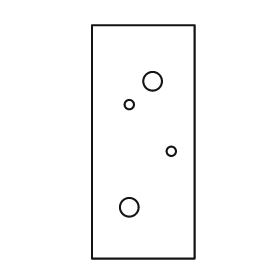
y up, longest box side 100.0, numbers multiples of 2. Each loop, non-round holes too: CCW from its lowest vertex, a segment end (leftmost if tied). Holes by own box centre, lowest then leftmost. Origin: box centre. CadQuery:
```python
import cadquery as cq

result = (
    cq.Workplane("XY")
    .moveTo(-22.0, -50.0)
    .lineTo(22.0, -50.0)
    .lineTo(22.0, 50.0)
    .lineTo(-22.0, 50.0)
    .close()
    .moveTo(-6.0, -28.0)
    .circle(4.0)
    .moveTo(12.0, -4.0)
    .circle(2.0)
    .moveTo(-6.0, 16.0)
    .circle(2.0)
    .moveTo(4.0, 26.0)
    .circle(4.0)
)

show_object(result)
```